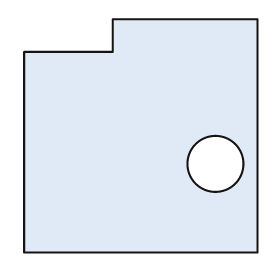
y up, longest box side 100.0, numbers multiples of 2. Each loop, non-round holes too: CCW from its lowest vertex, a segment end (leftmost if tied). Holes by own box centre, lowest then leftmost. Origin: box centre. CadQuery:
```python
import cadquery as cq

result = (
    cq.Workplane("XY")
    .moveTo(-50.0, -50.0)
    .lineTo(50.0, -50.0)
    .lineTo(50.0, 50.0)
    .lineTo(-12.0, 50.0)
    .lineTo(-12.0, 36.0)
    .lineTo(-50.0, 36.0)
    .close()
    .moveTo(32.0, -12.0)
    .circle(12.0)
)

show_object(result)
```